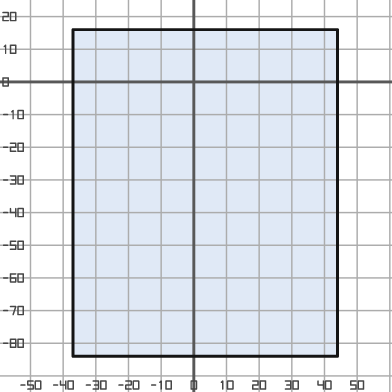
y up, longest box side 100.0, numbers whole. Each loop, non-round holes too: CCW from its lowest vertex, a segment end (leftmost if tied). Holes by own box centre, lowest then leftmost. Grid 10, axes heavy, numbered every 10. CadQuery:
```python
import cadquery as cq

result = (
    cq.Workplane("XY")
    .moveTo(-37.0, -84.0)
    .lineTo(44.0, -84.0)
    .lineTo(44.0, 16.0)
    .lineTo(-37.0, 16.0)
    .close()
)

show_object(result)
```